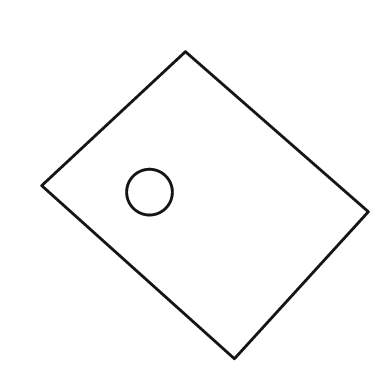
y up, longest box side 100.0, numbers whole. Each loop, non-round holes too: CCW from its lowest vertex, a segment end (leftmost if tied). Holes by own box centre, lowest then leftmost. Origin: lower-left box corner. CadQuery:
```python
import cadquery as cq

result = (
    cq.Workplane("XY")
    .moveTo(59.0, 0.0)
    .lineTo(100.0, 45.0)
    .lineTo(44.0, 94.0)
    .lineTo(0.0, 53.0)
    .close()
    .moveTo(33.0, 51.0)
    .circle(7.0)
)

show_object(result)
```